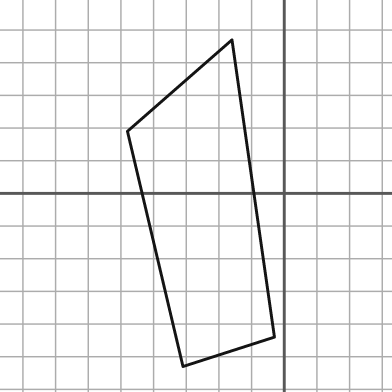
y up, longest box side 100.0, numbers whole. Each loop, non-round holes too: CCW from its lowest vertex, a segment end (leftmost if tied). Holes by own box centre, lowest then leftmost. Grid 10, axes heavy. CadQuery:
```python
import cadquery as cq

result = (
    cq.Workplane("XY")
    .moveTo(-31.0, -53.0)
    .lineTo(-3.0, -44.0)
    .lineTo(-16.0, 47.0)
    .lineTo(-48.0, 19.0)
    .close()
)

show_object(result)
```